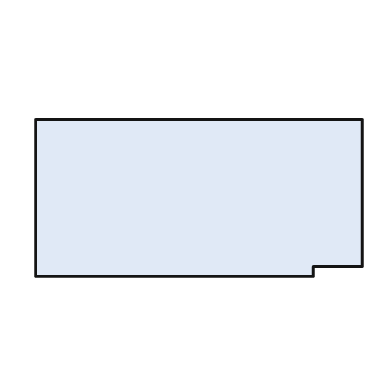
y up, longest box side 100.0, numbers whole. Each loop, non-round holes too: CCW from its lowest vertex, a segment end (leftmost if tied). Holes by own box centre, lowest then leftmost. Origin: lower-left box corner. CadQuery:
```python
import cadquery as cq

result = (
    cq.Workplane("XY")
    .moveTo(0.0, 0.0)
    .lineTo(85.0, 0.0)
    .lineTo(85.0, 3.0)
    .lineTo(100.0, 3.0)
    .lineTo(100.0, 48.0)
    .lineTo(0.0, 48.0)
    .close()
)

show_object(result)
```